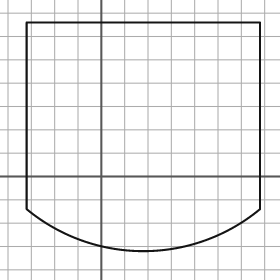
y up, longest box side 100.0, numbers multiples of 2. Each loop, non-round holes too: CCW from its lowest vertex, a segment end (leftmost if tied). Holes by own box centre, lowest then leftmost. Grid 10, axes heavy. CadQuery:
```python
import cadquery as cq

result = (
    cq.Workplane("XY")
    .moveTo(-32.0, -14.0)
    .threePointArc((18.0, -32.0), (68.0, -14.0))
    .lineTo(68.0, 66.0)
    .lineTo(-32.0, 66.0)
    .close()
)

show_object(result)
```